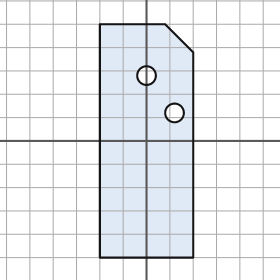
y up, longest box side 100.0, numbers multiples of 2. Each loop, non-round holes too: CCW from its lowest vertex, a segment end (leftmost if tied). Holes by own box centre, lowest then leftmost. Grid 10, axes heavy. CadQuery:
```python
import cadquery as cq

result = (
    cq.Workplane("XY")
    .moveTo(-20.0, -50.0)
    .lineTo(20.0, -50.0)
    .lineTo(20.0, 38.0)
    .lineTo(8.0, 50.0)
    .lineTo(-20.0, 50.0)
    .close()
    .moveTo(12.0, 12.0)
    .circle(4.0)
    .moveTo(0.0, 28.0)
    .circle(4.0)
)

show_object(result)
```